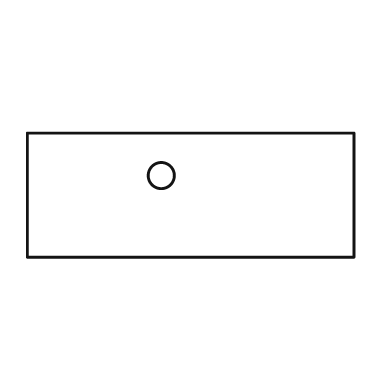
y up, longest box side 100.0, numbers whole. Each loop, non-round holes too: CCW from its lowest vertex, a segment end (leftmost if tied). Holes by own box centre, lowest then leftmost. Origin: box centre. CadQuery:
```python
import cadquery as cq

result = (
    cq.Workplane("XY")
    .moveTo(-50.0, -19.0)
    .lineTo(50.0, -19.0)
    .lineTo(50.0, 19.0)
    .lineTo(-50.0, 19.0)
    .close()
    .moveTo(-9.0, 6.0)
    .circle(4.0)
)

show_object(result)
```